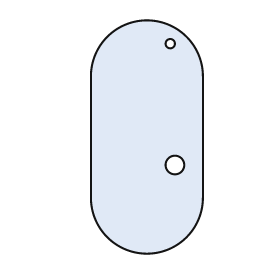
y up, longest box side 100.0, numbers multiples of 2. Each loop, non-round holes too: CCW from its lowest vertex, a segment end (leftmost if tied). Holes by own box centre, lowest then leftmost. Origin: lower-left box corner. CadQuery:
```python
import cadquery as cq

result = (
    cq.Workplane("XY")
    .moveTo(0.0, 24.0)
    .threePointArc((24.0, 0.0), (48.0, 24.0))
    .lineTo(48.0, 76.0)
    .threePointArc((24.0, 100.0), (0.0, 76.0))
    .close()
    .moveTo(36.0, 38.0)
    .circle(4.0)
    .moveTo(34.0, 90.0)
    .circle(2.0)
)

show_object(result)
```